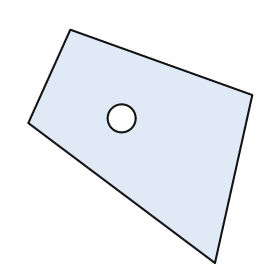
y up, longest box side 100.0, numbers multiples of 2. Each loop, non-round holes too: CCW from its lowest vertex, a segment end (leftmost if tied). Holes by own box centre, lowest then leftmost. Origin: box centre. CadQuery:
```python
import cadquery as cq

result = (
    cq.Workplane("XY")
    .moveTo(32.0, -50.0)
    .lineTo(48.0, 22.0)
    .lineTo(-30.0, 50.0)
    .lineTo(-48.0, 10.0)
    .close()
    .moveTo(-8.0, 12.0)
    .circle(6.0)
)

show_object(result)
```